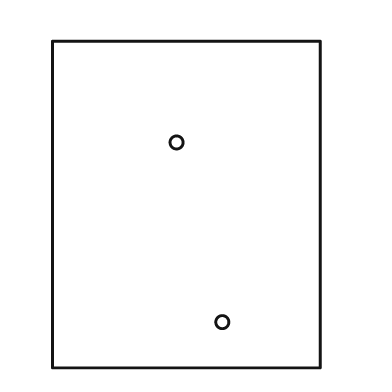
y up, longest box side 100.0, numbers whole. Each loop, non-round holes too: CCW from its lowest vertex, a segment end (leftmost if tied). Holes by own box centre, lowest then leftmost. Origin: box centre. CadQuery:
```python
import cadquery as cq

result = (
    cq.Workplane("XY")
    .moveTo(-41.0, -50.0)
    .lineTo(41.0, -50.0)
    .lineTo(41.0, 50.0)
    .lineTo(-41.0, 50.0)
    .close()
    .moveTo(11.0, -36.0)
    .circle(2.0)
    .moveTo(-3.0, 19.0)
    .circle(2.0)
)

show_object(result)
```